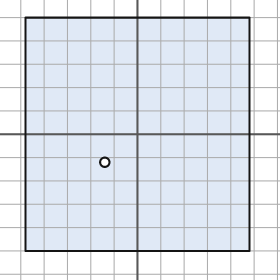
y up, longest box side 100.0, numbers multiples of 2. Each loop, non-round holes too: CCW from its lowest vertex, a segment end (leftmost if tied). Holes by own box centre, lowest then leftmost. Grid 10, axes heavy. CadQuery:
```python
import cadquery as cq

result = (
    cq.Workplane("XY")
    .moveTo(-48.0, -50.0)
    .lineTo(48.0, -50.0)
    .lineTo(48.0, 50.0)
    .lineTo(-48.0, 50.0)
    .close()
    .moveTo(-14.0, -12.0)
    .circle(2.0)
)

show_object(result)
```